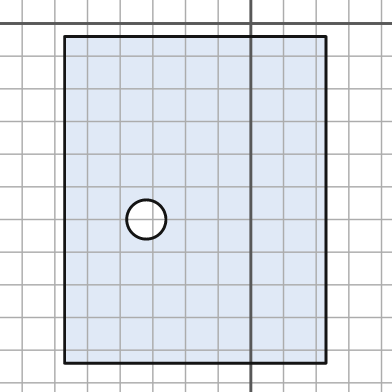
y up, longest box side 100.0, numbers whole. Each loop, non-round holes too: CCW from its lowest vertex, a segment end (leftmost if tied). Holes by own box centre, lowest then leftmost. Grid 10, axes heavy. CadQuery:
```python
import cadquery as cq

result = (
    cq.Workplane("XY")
    .moveTo(-57.0, -104.0)
    .lineTo(23.0, -104.0)
    .lineTo(23.0, -4.0)
    .lineTo(-57.0, -4.0)
    .close()
    .moveTo(-32.0, -60.0)
    .circle(6.0)
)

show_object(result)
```